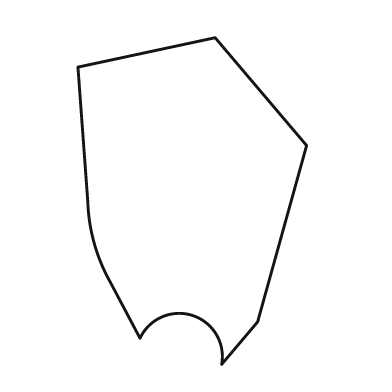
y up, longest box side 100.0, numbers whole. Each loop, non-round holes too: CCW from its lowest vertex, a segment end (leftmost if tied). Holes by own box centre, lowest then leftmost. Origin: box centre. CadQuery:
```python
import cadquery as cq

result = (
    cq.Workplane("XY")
    .moveTo(9.0, -50.0)
    .lineTo(20.0, -37.0)
    .lineTo(35.0, 17.0)
    .lineTo(7.0, 50.0)
    .lineTo(-35.0, 41.0)
    .lineTo(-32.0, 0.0)
    .threePointArc((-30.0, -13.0), (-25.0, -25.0))
    .lineTo(-16.0, -42.0)
    .threePointArc((0.0, -35.0), (9.0, -50.0))
    .close()
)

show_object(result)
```